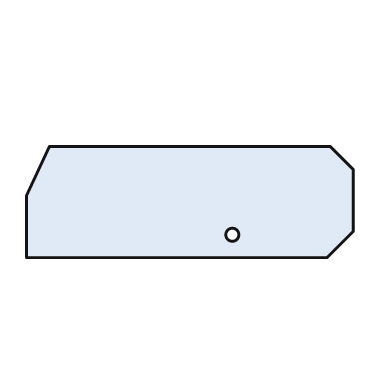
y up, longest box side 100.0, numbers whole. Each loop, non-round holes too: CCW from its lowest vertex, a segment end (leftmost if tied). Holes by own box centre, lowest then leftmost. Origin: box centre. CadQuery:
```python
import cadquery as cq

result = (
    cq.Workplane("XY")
    .moveTo(-50.0, -17.0)
    .lineTo(42.0, -17.0)
    .lineTo(50.0, -9.0)
    .lineTo(50.0, 10.0)
    .lineTo(43.0, 17.0)
    .lineTo(-43.0, 17.0)
    .lineTo(-50.0, 2.0)
    .close()
    .moveTo(13.0, -10.0)
    .circle(2.0)
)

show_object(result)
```